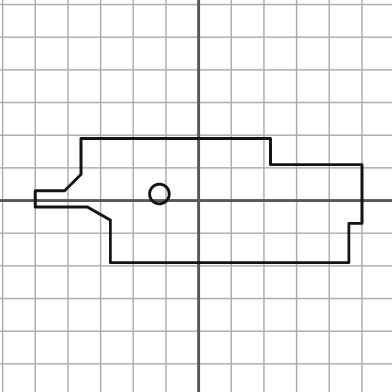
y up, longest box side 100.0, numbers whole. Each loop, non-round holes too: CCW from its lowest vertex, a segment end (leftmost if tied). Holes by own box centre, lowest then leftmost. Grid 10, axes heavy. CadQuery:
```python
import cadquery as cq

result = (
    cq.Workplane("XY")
    .moveTo(-27.0, -19.0)
    .lineTo(46.0, -19.0)
    .lineTo(46.0, -7.0)
    .lineTo(50.0, -7.0)
    .lineTo(50.0, 11.0)
    .lineTo(22.0, 11.0)
    .lineTo(22.0, 19.0)
    .lineTo(-36.0, 19.0)
    .lineTo(-36.0, 8.0)
    .lineTo(-41.0, 3.0)
    .lineTo(-50.0, 3.0)
    .lineTo(-50.0, -2.0)
    .lineTo(-34.0, -2.0)
    .lineTo(-27.0, -6.0)
    .close()
    .moveTo(-12.0, 2.0)
    .circle(3.0)
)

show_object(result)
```